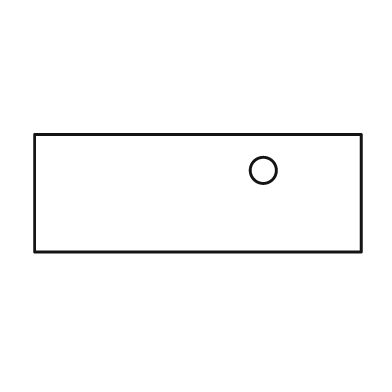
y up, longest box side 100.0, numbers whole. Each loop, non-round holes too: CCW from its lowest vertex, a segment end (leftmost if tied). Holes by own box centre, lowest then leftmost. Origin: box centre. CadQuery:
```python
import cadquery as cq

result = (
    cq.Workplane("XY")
    .moveTo(-50.0, -18.0)
    .lineTo(50.0, -18.0)
    .lineTo(50.0, 18.0)
    .lineTo(-50.0, 18.0)
    .close()
    .moveTo(20.0, 7.0)
    .circle(4.0)
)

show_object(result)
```